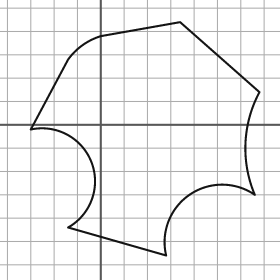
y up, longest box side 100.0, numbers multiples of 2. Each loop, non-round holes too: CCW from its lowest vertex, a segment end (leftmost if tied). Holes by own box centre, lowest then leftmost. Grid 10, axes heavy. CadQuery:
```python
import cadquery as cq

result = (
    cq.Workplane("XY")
    .moveTo(28.0, -56.0)
    .threePointArc((38.0, -30.0), (66.0, -30.0))
    .threePointArc((62.0, -8.0), (68.0, 14.0))
    .lineTo(34.0, 44.0)
    .lineTo(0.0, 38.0)
    .threePointArc((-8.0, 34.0), (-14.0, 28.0))
    .lineTo(-30.0, -2.0)
    .threePointArc((-4.0, -16.0), (-14.0, -44.0))
    .close()
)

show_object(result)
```